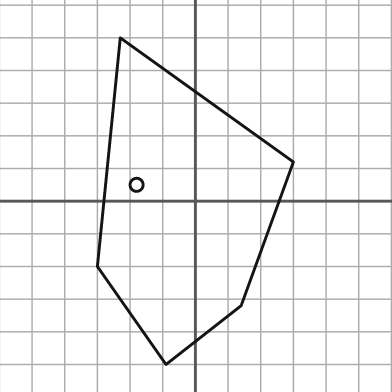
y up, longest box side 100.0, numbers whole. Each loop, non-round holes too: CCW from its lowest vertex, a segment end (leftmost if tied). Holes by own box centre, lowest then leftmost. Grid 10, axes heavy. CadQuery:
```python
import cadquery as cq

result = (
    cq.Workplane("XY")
    .moveTo(-9.0, -50.0)
    .lineTo(14.0, -32.0)
    .lineTo(30.0, 12.0)
    .lineTo(-23.0, 50.0)
    .lineTo(-30.0, -20.0)
    .close()
    .moveTo(-18.0, 5.0)
    .circle(2.0)
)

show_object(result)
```